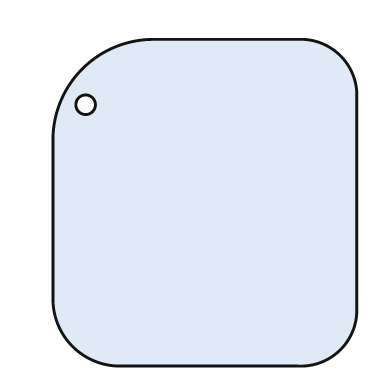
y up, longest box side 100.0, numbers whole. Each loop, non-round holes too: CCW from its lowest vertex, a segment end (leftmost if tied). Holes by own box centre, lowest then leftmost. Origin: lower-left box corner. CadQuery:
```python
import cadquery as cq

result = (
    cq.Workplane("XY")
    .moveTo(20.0, 0.0)
    .lineTo(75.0, 0.0)
    .threePointArc((88.0, 5.0), (93.0, 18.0))
    .lineTo(93.0, 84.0)
    .threePointArc((88.0, 95.0), (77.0, 100.0))
    .lineTo(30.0, 100.0)
    .threePointArc((9.0, 91.0), (0.0, 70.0))
    .lineTo(0.0, 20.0)
    .threePointArc((6.0, 6.0), (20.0, 0.0))
    .close()
    .moveTo(10.0, 80.0)
    .circle(3.0)
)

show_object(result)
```